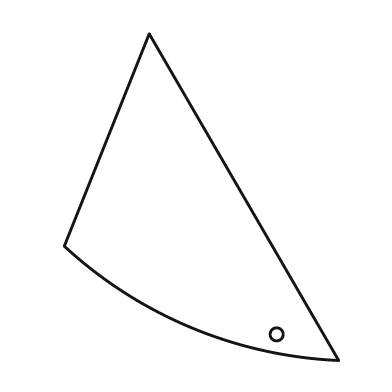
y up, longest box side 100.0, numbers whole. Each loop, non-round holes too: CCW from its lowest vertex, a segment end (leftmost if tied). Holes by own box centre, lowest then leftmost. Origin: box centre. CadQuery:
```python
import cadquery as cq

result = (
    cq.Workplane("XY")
    .moveTo(42.0, -50.0)
    .lineTo(-16.0, 50.0)
    .lineTo(-42.0, -15.0)
    .threePointArc((-3.0, -40.0), (42.0, -50.0))
    .close()
    .moveTo(23.0, -42.0)
    .circle(2.0)
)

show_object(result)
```